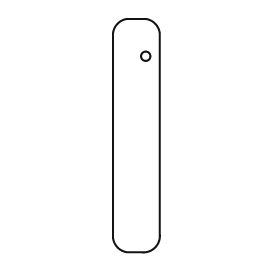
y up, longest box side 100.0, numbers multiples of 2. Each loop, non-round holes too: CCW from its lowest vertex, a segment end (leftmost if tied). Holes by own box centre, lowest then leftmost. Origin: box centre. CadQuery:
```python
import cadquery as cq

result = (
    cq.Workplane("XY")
    .moveTo(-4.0, -50.0)
    .lineTo(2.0, -50.0)
    .threePointArc((8.0, -48.0), (10.0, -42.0))
    .lineTo(10.0, 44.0)
    .threePointArc((8.0, 48.0), (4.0, 50.0))
    .lineTo(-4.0, 50.0)
    .threePointArc((-8.0, 48.0), (-10.0, 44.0))
    .lineTo(-10.0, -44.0)
    .threePointArc((-8.0, -48.0), (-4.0, -50.0))
    .close()
    .moveTo(4.0, 34.0)
    .circle(2.0)
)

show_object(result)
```